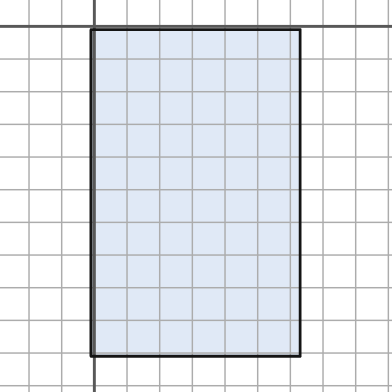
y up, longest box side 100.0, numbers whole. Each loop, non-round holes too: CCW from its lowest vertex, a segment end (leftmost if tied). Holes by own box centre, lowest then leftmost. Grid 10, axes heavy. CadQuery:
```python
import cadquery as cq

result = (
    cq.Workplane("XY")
    .moveTo(-1.0, -101.0)
    .lineTo(63.0, -101.0)
    .lineTo(63.0, -1.0)
    .lineTo(-1.0, -1.0)
    .close()
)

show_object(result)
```